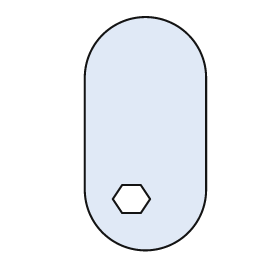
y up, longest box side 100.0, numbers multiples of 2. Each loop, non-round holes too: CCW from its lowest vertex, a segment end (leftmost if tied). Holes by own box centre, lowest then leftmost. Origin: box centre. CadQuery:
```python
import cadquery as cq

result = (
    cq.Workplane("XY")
    .moveTo(-26.0, -24.0)
    .threePointArc((0.0, -50.0), (26.0, -24.0))
    .lineTo(26.0, 24.0)
    .threePointArc((0.0, 50.0), (-26.0, 24.0))
    .close()
    .moveTo(-10.0, -34.0)
    .lineTo(-2.0, -34.0)
    .lineTo(2.0, -28.0)
    .lineTo(-2.0, -22.0)
    .lineTo(-10.0, -22.0)
    .lineTo(-14.0, -28.0)
    .close()
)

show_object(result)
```